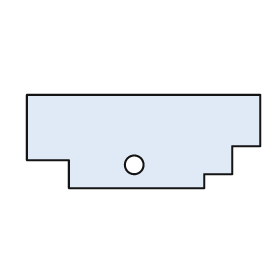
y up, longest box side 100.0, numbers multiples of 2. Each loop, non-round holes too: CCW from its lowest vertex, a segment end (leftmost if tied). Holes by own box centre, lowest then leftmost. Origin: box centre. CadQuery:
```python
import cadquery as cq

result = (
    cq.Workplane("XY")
    .moveTo(-32.0, -20.0)
    .lineTo(26.0, -20.0)
    .lineTo(26.0, -14.0)
    .lineTo(38.0, -14.0)
    .lineTo(38.0, -2.0)
    .lineTo(50.0, -2.0)
    .lineTo(50.0, 20.0)
    .lineTo(-50.0, 20.0)
    .lineTo(-50.0, -8.0)
    .lineTo(-32.0, -8.0)
    .close()
    .moveTo(-4.0, -10.0)
    .circle(4.0)
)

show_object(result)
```